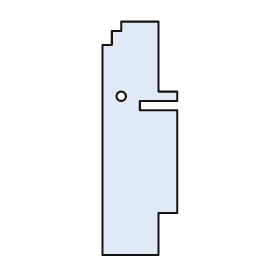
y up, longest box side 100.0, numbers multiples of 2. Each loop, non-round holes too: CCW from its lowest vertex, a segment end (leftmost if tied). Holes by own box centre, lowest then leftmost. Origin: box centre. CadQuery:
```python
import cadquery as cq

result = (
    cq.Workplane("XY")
    .moveTo(-16.0, -50.0)
    .lineTo(8.0, -50.0)
    .lineTo(8.0, -32.0)
    .lineTo(16.0, -32.0)
    .lineTo(16.0, 12.0)
    .lineTo(0.0, 12.0)
    .lineTo(0.0, 16.0)
    .lineTo(16.0, 16.0)
    .lineTo(16.0, 20.0)
    .lineTo(8.0, 20.0)
    .lineTo(8.0, 50.0)
    .lineTo(-8.0, 50.0)
    .lineTo(-8.0, 46.0)
    .lineTo(-12.0, 46.0)
    .lineTo(-12.0, 40.0)
    .lineTo(-16.0, 40.0)
    .close()
    .moveTo(-8.0, 18.0)
    .circle(2.0)
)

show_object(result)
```